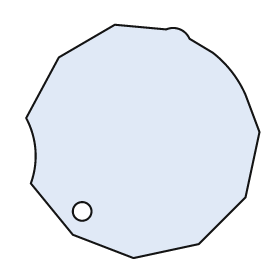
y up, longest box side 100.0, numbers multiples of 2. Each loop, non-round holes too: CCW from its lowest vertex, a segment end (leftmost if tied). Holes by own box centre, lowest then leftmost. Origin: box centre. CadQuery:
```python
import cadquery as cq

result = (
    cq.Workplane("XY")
    .moveTo(-4.0, -50.0)
    .lineTo(24.0, -44.0)
    .lineTo(44.0, -24.0)
    .lineTo(50.0, 4.0)
    .lineTo(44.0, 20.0)
    .threePointArc((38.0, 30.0), (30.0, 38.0))
    .lineTo(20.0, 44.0)
    .threePointArc((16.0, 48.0), (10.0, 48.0))
    .lineTo(-12.0, 50.0)
    .lineTo(-36.0, 36.0)
    .lineTo(-50.0, 10.0)
    .threePointArc((-46.0, -4.0), (-48.0, -18.0))
    .lineTo(-30.0, -40.0)
    .close()
    .moveTo(-26.0, -30.0)
    .circle(4.0)
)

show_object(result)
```